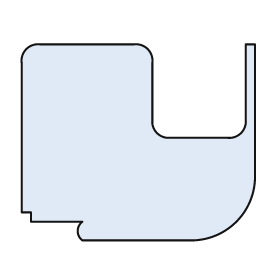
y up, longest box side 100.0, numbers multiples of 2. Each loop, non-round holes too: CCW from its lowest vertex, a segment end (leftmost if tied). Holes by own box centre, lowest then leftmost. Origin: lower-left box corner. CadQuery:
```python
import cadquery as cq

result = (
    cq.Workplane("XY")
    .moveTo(26.0, 0.0)
    .lineTo(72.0, 0.0)
    .threePointArc((92.0, 8.0), (100.0, 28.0))
    .lineTo(100.0, 84.0)
    .lineTo(96.0, 84.0)
    .lineTo(96.0, 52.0)
    .threePointArc((94.0, 46.0), (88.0, 44.0))
    .lineTo(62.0, 44.0)
    .threePointArc((58.0, 46.0), (56.0, 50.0))
    .lineTo(56.0, 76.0)
    .threePointArc((54.0, 82.0), (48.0, 84.0))
    .lineTo(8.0, 84.0)
    .threePointArc((2.0, 82.0), (0.0, 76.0))
    .lineTo(0.0, 12.0)
    .lineTo(4.0, 12.0)
    .lineTo(4.0, 8.0)
    .lineTo(26.0, 8.0)
    .threePointArc((24.0, 4.0), (26.0, 0.0))
    .close()
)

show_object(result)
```